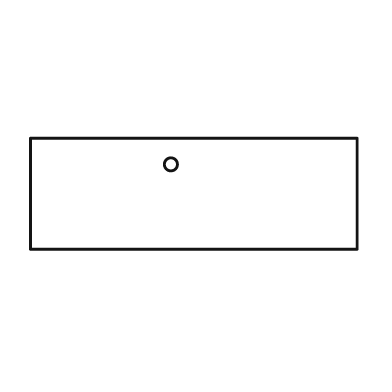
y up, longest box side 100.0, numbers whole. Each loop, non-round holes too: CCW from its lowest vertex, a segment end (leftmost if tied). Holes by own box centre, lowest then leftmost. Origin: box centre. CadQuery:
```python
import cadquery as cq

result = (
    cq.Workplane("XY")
    .moveTo(-50.0, -17.0)
    .lineTo(50.0, -17.0)
    .lineTo(50.0, 17.0)
    .lineTo(-50.0, 17.0)
    .close()
    .moveTo(-7.0, 9.0)
    .circle(2.0)
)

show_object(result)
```